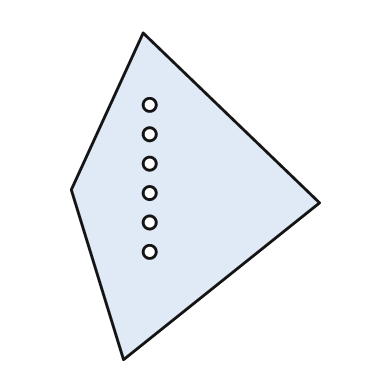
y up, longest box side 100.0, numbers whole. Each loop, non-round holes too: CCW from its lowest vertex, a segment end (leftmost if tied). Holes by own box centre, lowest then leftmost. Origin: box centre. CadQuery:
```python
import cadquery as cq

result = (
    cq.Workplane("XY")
    .moveTo(-22.0, -50.0)
    .lineTo(38.0, -2.0)
    .lineTo(-16.0, 50.0)
    .lineTo(-38.0, 2.0)
    .close()
    .moveTo(-14.0, -17.0)
    .circle(2.0)
    .moveTo(-14.0, -8.0)
    .circle(2.0)
    .moveTo(-14.0, 1.0)
    .circle(2.0)
    .moveTo(-14.0, 10.0)
    .circle(2.0)
    .moveTo(-14.0, 19.0)
    .circle(2.0)
    .moveTo(-14.0, 28.0)
    .circle(2.0)
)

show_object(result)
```